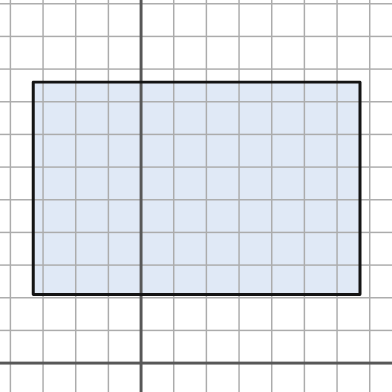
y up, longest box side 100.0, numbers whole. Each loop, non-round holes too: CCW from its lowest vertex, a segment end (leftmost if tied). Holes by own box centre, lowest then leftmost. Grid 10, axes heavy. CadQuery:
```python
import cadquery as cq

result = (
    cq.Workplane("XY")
    .moveTo(-33.0, 21.0)
    .lineTo(67.0, 21.0)
    .lineTo(67.0, 86.0)
    .lineTo(-33.0, 86.0)
    .close()
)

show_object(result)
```